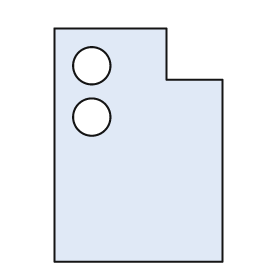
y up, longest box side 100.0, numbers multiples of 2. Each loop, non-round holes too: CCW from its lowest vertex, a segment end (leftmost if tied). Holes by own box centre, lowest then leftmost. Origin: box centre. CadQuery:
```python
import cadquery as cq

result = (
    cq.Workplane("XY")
    .moveTo(-36.0, -50.0)
    .lineTo(36.0, -50.0)
    .lineTo(36.0, 28.0)
    .lineTo(12.0, 28.0)
    .lineTo(12.0, 50.0)
    .lineTo(-36.0, 50.0)
    .close()
    .moveTo(-20.0, 12.0)
    .circle(8.0)
    .moveTo(-20.0, 34.0)
    .circle(8.0)
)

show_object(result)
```